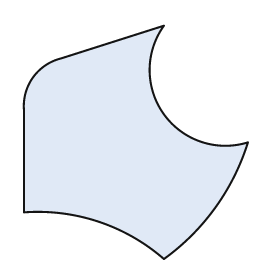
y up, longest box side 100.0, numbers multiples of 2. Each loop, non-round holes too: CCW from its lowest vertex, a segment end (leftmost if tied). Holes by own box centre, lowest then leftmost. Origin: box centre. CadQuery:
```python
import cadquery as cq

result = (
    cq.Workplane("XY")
    .moveTo(12.0, -50.0)
    .threePointArc((34.0, -28.0), (48.0, 0.0))
    .threePointArc((12.0, 12.0), (12.0, 50.0))
    .lineTo(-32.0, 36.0)
    .threePointArc((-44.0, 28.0), (-48.0, 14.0))
    .lineTo(-48.0, -30.0)
    .threePointArc((-16.0, -34.0), (12.0, -50.0))
    .close()
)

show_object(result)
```